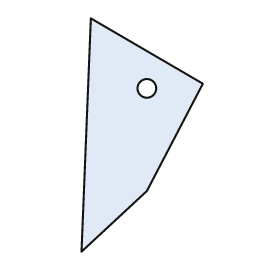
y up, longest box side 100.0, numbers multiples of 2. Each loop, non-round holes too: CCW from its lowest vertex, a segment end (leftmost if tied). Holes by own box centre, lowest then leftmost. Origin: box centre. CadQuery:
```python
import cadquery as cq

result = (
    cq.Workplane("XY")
    .moveTo(-26.0, -50.0)
    .lineTo(2.0, -24.0)
    .lineTo(26.0, 22.0)
    .lineTo(-22.0, 50.0)
    .close()
    .moveTo(2.0, 20.0)
    .circle(4.0)
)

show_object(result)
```